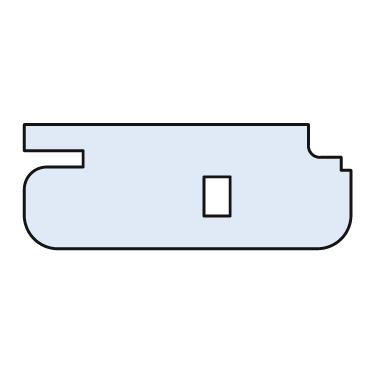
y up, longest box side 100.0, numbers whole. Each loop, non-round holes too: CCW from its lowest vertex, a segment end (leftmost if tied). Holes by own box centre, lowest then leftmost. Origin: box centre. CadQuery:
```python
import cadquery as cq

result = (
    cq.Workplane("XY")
    .moveTo(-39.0, -19.0)
    .lineTo(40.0, -19.0)
    .threePointArc((47.0, -16.0), (50.0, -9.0))
    .lineTo(50.0, 5.0)
    .lineTo(47.0, 5.0)
    .lineTo(47.0, 9.0)
    .lineTo(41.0, 9.0)
    .threePointArc((38.0, 10.0), (37.0, 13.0))
    .lineTo(37.0, 19.0)
    .lineTo(-50.0, 19.0)
    .lineTo(-50.0, 11.0)
    .lineTo(-32.0, 11.0)
    .lineTo(-32.0, 6.0)
    .lineTo(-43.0, 6.0)
    .threePointArc((-48.0, 4.0), (-50.0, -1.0))
    .lineTo(-50.0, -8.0)
    .threePointArc((-47.0, -16.0), (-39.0, -19.0))
    .close()
    .moveTo(5.0, -9.0)
    .lineTo(13.0, -9.0)
    .lineTo(13.0, 3.0)
    .lineTo(5.0, 3.0)
    .close()
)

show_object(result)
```